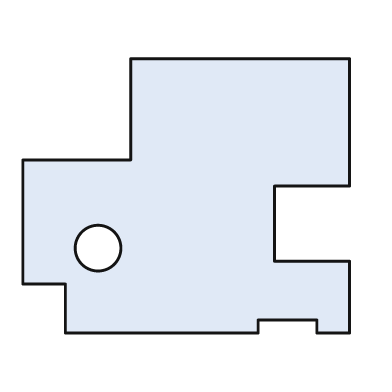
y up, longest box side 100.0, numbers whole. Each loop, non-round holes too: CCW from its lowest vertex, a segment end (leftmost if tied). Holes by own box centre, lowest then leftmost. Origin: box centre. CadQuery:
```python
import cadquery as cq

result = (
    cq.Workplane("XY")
    .moveTo(-37.0, -42.0)
    .lineTo(22.0, -42.0)
    .lineTo(22.0, -38.0)
    .lineTo(40.0, -38.0)
    .lineTo(40.0, -42.0)
    .lineTo(50.0, -42.0)
    .lineTo(50.0, -20.0)
    .lineTo(27.0, -20.0)
    .lineTo(27.0, 3.0)
    .lineTo(50.0, 3.0)
    .lineTo(50.0, 42.0)
    .lineTo(-17.0, 42.0)
    .lineTo(-17.0, 11.0)
    .lineTo(-50.0, 11.0)
    .lineTo(-50.0, -27.0)
    .lineTo(-37.0, -27.0)
    .close()
    .moveTo(-27.0, -16.0)
    .circle(7.0)
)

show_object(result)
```